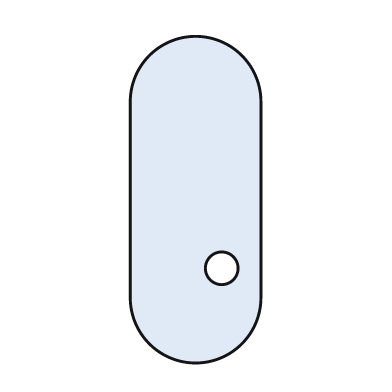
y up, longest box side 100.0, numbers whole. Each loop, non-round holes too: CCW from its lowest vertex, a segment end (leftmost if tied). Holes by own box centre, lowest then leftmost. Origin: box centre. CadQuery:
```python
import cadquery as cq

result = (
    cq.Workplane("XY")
    .moveTo(-20.0, -30.0)
    .threePointArc((0.0, -50.0), (20.0, -30.0))
    .lineTo(20.0, 30.0)
    .threePointArc((0.0, 50.0), (-20.0, 30.0))
    .close()
    .moveTo(8.0, -21.0)
    .circle(5.0)
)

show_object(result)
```